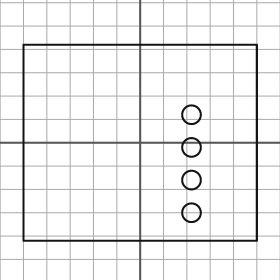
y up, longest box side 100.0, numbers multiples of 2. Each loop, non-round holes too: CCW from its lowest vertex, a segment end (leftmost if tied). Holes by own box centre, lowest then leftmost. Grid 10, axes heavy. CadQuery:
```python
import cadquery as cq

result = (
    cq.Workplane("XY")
    .moveTo(-50.0, -42.0)
    .lineTo(50.0, -42.0)
    .lineTo(50.0, 42.0)
    .lineTo(-50.0, 42.0)
    .close()
    .moveTo(22.0, -30.0)
    .circle(4.0)
    .moveTo(22.0, -16.0)
    .circle(4.0)
    .moveTo(22.0, -2.0)
    .circle(4.0)
    .moveTo(22.0, 12.0)
    .circle(4.0)
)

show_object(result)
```